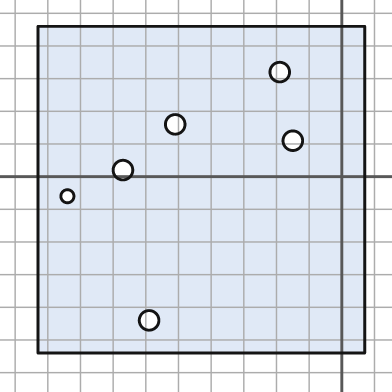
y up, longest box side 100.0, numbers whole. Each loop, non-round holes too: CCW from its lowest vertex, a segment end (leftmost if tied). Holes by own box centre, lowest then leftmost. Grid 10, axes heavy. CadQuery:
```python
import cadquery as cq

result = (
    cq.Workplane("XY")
    .moveTo(-93.0, -54.0)
    .lineTo(7.0, -54.0)
    .lineTo(7.0, 46.0)
    .lineTo(-93.0, 46.0)
    .close()
    .moveTo(-59.0, -44.0)
    .circle(3.0)
    .moveTo(-84.0, -6.0)
    .circle(2.0)
    .moveTo(-67.0, 2.0)
    .circle(3.0)
    .moveTo(-15.0, 11.0)
    .circle(3.0)
    .moveTo(-51.0, 16.0)
    .circle(3.0)
    .moveTo(-19.0, 32.0)
    .circle(3.0)
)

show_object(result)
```